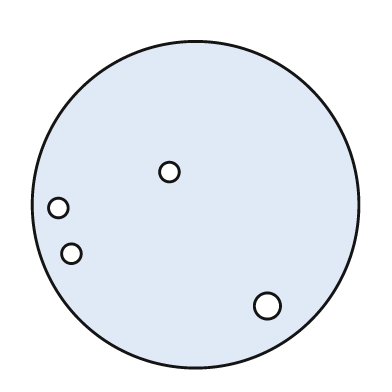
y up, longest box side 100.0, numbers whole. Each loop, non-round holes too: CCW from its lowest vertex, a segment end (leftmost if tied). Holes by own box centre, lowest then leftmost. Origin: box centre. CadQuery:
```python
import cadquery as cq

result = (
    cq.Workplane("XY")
    .moveTo(0.0, 0.0)
    .circle(50.0)
    .moveTo(22.0, -31.0)
    .circle(4.0)
    .moveTo(-38.0, -15.0)
    .circle(3.0)
    .moveTo(-42.0, -1.0)
    .circle(3.0)
    .moveTo(-8.0, 10.0)
    .circle(3.0)
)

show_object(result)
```